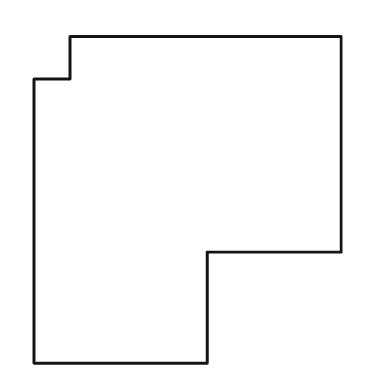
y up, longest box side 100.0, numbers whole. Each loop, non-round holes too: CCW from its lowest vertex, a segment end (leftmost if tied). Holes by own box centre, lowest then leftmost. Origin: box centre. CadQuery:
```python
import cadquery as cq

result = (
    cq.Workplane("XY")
    .moveTo(-47.0, -50.0)
    .lineTo(6.0, -50.0)
    .lineTo(6.0, -16.0)
    .lineTo(47.0, -16.0)
    .lineTo(47.0, 50.0)
    .lineTo(-36.0, 50.0)
    .lineTo(-36.0, 37.0)
    .lineTo(-47.0, 37.0)
    .close()
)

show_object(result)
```